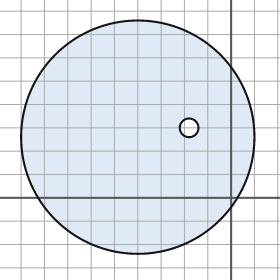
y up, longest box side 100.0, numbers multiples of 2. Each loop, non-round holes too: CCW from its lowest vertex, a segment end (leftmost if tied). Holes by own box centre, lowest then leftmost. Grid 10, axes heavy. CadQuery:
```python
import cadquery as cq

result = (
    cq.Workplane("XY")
    .moveTo(-40.0, 26.0)
    .circle(50.0)
    .moveTo(-18.0, 30.0)
    .circle(4.0)
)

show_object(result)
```